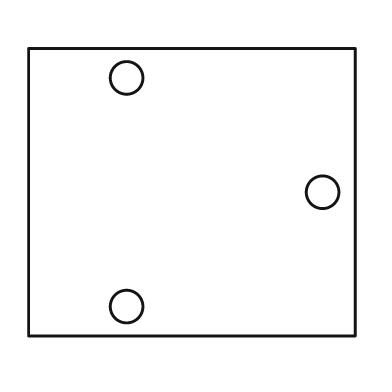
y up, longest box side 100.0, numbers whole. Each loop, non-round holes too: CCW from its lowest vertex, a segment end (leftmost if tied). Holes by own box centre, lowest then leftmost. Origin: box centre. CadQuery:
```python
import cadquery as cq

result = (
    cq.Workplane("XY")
    .moveTo(-50.0, -44.0)
    .lineTo(50.0, -44.0)
    .lineTo(50.0, 44.0)
    .lineTo(-50.0, 44.0)
    .close()
    .moveTo(-20.0, -35.0)
    .circle(5.0)
    .moveTo(40.0, 0.0)
    .circle(5.0)
    .moveTo(-20.0, 35.0)
    .circle(5.0)
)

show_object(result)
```